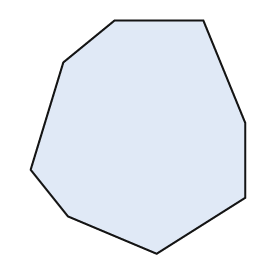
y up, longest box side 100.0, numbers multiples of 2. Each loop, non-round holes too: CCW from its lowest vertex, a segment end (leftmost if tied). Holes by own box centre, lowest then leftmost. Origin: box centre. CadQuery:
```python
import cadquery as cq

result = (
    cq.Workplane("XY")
    .moveTo(8.0, -50.0)
    .lineTo(46.0, -26.0)
    .lineTo(46.0, 6.0)
    .lineTo(28.0, 50.0)
    .lineTo(-10.0, 50.0)
    .lineTo(-32.0, 32.0)
    .lineTo(-46.0, -14.0)
    .lineTo(-30.0, -34.0)
    .close()
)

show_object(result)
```